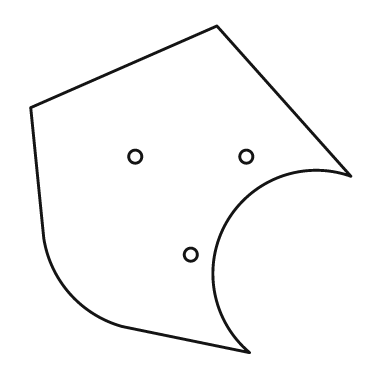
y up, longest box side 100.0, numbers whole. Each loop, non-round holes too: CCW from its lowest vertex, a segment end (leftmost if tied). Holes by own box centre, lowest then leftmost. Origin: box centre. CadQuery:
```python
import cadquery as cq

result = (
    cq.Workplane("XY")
    .moveTo(18.0, -50.0)
    .threePointArc((11.0, -10.0), (49.0, 4.0))
    .lineTo(8.0, 50.0)
    .lineTo(-49.0, 25.0)
    .lineTo(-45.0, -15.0)
    .threePointArc((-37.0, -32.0), (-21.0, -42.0))
    .close()
    .moveTo(0.0, -20.0)
    .circle(2.0)
    .moveTo(-17.0, 10.0)
    .circle(2.0)
    .moveTo(17.0, 10.0)
    .circle(2.0)
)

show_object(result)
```